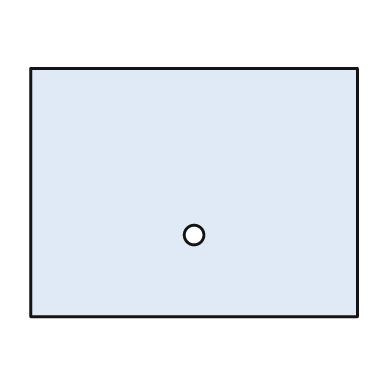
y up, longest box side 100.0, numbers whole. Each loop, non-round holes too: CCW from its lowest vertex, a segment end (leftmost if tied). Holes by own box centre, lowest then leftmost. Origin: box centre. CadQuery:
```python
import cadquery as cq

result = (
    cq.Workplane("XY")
    .moveTo(-50.0, -38.0)
    .lineTo(50.0, -38.0)
    .lineTo(50.0, 38.0)
    .lineTo(-50.0, 38.0)
    .close()
    .moveTo(0.0, -13.0)
    .circle(3.0)
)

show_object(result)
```